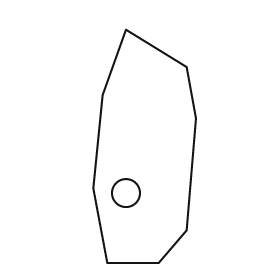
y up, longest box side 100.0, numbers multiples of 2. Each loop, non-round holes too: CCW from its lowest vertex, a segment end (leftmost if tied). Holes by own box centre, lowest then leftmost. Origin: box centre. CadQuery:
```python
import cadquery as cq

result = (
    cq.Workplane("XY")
    .moveTo(-16.0, -50.0)
    .lineTo(6.0, -50.0)
    .lineTo(18.0, -36.0)
    .lineTo(22.0, 12.0)
    .lineTo(18.0, 34.0)
    .lineTo(-8.0, 50.0)
    .lineTo(-18.0, 22.0)
    .lineTo(-22.0, -18.0)
    .close()
    .moveTo(-8.0, -20.0)
    .circle(6.0)
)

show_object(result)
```